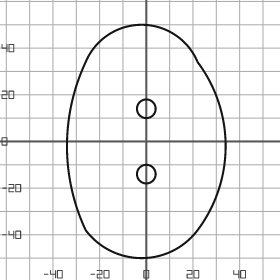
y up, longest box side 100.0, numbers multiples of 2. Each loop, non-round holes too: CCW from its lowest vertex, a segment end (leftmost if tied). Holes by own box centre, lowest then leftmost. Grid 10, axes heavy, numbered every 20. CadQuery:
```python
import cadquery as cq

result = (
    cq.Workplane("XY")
    .moveTo(-26.0, -38.0)
    .threePointArc((-2.0, -50.0), (22.0, -38.0))
    .threePointArc((34.0, -2.0), (22.0, 34.0))
    .threePointArc((-2.0, 50.0), (-26.0, 34.0))
    .threePointArc((-34.0, -2.0), (-26.0, -38.0))
    .close()
    .moveTo(0.0, -14.0)
    .circle(4.0)
    .moveTo(0.0, 14.0)
    .circle(4.0)
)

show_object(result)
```